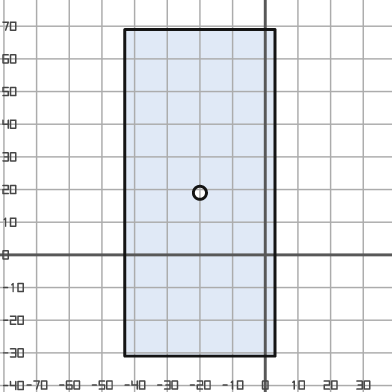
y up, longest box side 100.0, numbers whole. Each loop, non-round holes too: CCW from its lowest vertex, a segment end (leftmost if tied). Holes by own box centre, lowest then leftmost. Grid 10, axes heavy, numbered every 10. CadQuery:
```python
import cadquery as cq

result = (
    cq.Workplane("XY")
    .moveTo(-43.0, -31.0)
    .lineTo(3.0, -31.0)
    .lineTo(3.0, 69.0)
    .lineTo(-43.0, 69.0)
    .close()
    .moveTo(-20.0, 19.0)
    .circle(2.0)
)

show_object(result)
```